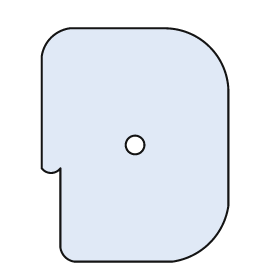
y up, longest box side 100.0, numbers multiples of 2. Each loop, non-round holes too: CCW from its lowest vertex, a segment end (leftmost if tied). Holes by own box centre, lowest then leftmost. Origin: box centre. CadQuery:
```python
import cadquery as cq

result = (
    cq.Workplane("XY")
    .moveTo(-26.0, -50.0)
    .lineTo(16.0, -50.0)
    .threePointArc((32.0, -42.0), (40.0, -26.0))
    .lineTo(40.0, 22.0)
    .threePointArc((32.0, 42.0), (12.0, 50.0))
    .lineTo(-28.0, 50.0)
    .threePointArc((-36.0, 46.0), (-40.0, 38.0))
    .lineTo(-40.0, -10.0)
    .threePointArc((-36.0, -12.0), (-32.0, -10.0))
    .lineTo(-32.0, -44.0)
    .threePointArc((-30.0, -48.0), (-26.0, -50.0))
    .close()
    .moveTo(0.0, 0.0)
    .circle(4.0)
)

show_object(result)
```